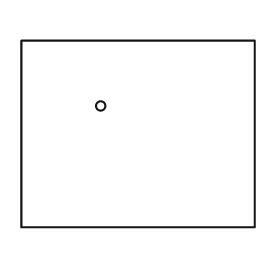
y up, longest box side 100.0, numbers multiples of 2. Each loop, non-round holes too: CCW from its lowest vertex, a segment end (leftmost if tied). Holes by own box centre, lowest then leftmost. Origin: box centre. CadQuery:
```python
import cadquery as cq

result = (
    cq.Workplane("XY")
    .moveTo(-50.0, -40.0)
    .lineTo(50.0, -40.0)
    .lineTo(50.0, 40.0)
    .lineTo(-50.0, 40.0)
    .close()
    .moveTo(-16.0, 12.0)
    .circle(2.0)
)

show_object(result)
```